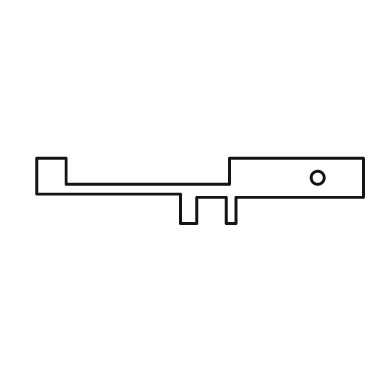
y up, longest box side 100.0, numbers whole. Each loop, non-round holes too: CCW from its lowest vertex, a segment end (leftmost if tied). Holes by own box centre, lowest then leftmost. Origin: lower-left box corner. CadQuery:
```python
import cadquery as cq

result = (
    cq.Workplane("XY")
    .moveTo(44.0, 0.0)
    .lineTo(49.0, 0.0)
    .lineTo(49.0, 8.0)
    .lineTo(58.0, 8.0)
    .lineTo(58.0, 0.0)
    .lineTo(61.0, 0.0)
    .lineTo(61.0, 8.0)
    .lineTo(100.0, 8.0)
    .lineTo(100.0, 20.0)
    .lineTo(59.0, 20.0)
    .lineTo(59.0, 12.0)
    .lineTo(9.0, 12.0)
    .lineTo(9.0, 20.0)
    .lineTo(0.0, 20.0)
    .lineTo(0.0, 9.0)
    .lineTo(44.0, 9.0)
    .close()
    .moveTo(86.0, 14.0)
    .circle(2.0)
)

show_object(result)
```